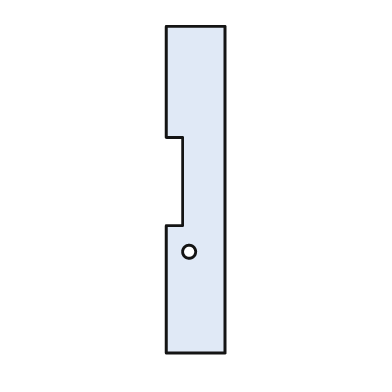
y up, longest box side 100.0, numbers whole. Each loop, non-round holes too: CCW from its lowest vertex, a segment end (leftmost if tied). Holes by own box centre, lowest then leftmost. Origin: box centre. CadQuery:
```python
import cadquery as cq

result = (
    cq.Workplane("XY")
    .moveTo(-9.0, -50.0)
    .lineTo(9.0, -50.0)
    .lineTo(9.0, 50.0)
    .lineTo(-9.0, 50.0)
    .lineTo(-9.0, 16.0)
    .lineTo(-4.0, 16.0)
    .lineTo(-4.0, -11.0)
    .lineTo(-9.0, -11.0)
    .close()
    .moveTo(-2.0, -19.0)
    .circle(2.0)
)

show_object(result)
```